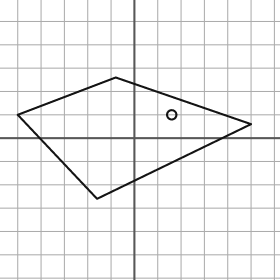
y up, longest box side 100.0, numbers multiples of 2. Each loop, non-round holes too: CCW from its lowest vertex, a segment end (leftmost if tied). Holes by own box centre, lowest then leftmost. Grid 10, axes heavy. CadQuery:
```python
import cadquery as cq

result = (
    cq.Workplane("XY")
    .moveTo(-16.0, -26.0)
    .lineTo(50.0, 6.0)
    .lineTo(-8.0, 26.0)
    .lineTo(-50.0, 10.0)
    .close()
    .moveTo(16.0, 10.0)
    .circle(2.0)
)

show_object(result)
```